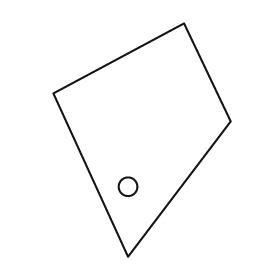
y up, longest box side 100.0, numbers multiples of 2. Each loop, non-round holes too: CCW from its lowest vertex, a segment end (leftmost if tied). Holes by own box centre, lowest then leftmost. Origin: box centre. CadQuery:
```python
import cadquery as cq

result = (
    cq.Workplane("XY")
    .moveTo(-6.0, -50.0)
    .lineTo(38.0, 8.0)
    .lineTo(18.0, 50.0)
    .lineTo(-38.0, 20.0)
    .close()
    .moveTo(-6.0, -20.0)
    .circle(4.0)
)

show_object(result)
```